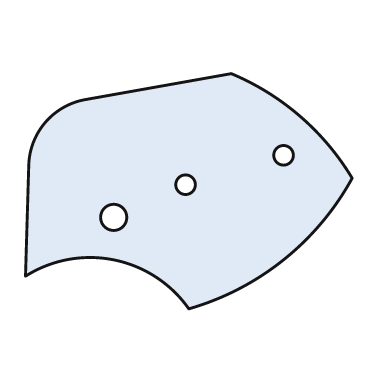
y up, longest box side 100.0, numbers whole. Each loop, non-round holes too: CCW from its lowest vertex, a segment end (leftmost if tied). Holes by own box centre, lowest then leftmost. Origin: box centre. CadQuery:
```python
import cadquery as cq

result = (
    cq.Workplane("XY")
    .moveTo(0.0, -36.0)
    .threePointArc((29.0, -21.0), (50.0, 4.0))
    .threePointArc((34.0, 23.0), (13.0, 36.0))
    .lineTo(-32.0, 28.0)
    .threePointArc((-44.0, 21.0), (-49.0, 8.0))
    .lineTo(-50.0, -26.0)
    .threePointArc((-23.0, -21.0), (0.0, -36.0))
    .close()
    .moveTo(-23.0, -8.0)
    .circle(4.0)
    .moveTo(-1.0, 2.0)
    .circle(3.0)
    .moveTo(29.0, 11.0)
    .circle(3.0)
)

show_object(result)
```